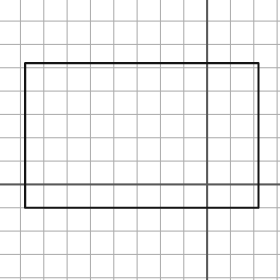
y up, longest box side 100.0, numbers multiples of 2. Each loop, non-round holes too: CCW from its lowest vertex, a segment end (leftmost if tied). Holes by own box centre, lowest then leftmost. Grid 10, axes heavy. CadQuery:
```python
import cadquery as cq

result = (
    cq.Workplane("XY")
    .moveTo(-78.0, -10.0)
    .lineTo(22.0, -10.0)
    .lineTo(22.0, 52.0)
    .lineTo(-78.0, 52.0)
    .close()
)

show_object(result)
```